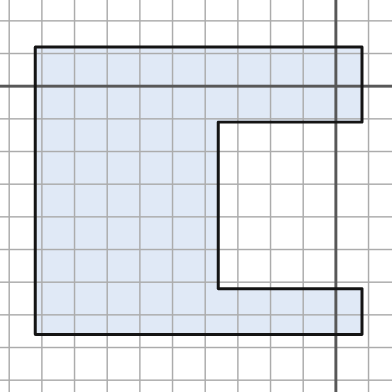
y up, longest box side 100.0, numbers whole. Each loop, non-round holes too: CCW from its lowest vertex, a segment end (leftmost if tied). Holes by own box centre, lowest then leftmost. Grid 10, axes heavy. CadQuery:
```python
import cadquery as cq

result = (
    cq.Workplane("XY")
    .moveTo(-92.0, -76.0)
    .lineTo(8.0, -76.0)
    .lineTo(8.0, -62.0)
    .lineTo(-36.0, -62.0)
    .lineTo(-36.0, -11.0)
    .lineTo(8.0, -11.0)
    .lineTo(8.0, 12.0)
    .lineTo(-92.0, 12.0)
    .close()
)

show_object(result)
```